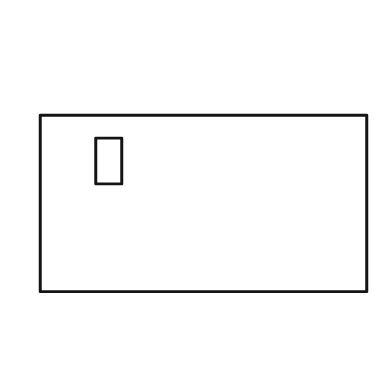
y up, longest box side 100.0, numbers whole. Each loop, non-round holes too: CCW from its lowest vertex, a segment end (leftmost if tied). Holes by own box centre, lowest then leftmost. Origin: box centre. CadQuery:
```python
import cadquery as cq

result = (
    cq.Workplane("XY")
    .moveTo(-50.0, -27.0)
    .lineTo(50.0, -27.0)
    .lineTo(50.0, 27.0)
    .lineTo(-50.0, 27.0)
    .close()
    .moveTo(-33.0, 6.0)
    .lineTo(-25.0, 6.0)
    .lineTo(-25.0, 20.0)
    .lineTo(-33.0, 20.0)
    .close()
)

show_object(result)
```